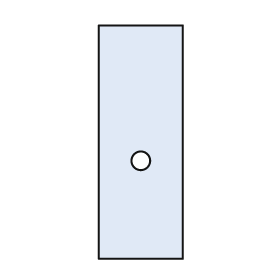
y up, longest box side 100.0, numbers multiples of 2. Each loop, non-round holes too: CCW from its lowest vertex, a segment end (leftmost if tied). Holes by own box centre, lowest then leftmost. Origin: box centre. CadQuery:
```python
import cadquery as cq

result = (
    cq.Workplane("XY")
    .moveTo(-18.0, -50.0)
    .lineTo(18.0, -50.0)
    .lineTo(18.0, 50.0)
    .lineTo(-18.0, 50.0)
    .close()
    .moveTo(0.0, -8.0)
    .circle(4.0)
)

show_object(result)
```